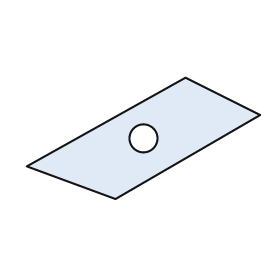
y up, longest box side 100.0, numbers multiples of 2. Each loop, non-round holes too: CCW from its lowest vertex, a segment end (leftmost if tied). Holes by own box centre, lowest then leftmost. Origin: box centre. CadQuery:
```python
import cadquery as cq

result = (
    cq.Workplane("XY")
    .moveTo(-12.0, -26.0)
    .lineTo(50.0, 10.0)
    .lineTo(18.0, 26.0)
    .lineTo(-50.0, -12.0)
    .close()
    .moveTo(0.0, 0.0)
    .circle(6.0)
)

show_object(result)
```